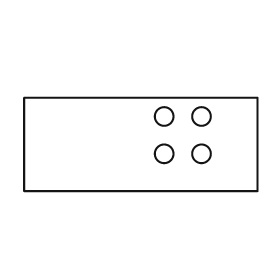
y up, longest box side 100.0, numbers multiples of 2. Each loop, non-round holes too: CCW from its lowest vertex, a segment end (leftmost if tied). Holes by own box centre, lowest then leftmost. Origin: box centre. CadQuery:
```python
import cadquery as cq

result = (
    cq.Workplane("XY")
    .moveTo(-50.0, -20.0)
    .lineTo(50.0, -20.0)
    .lineTo(50.0, 20.0)
    .lineTo(-50.0, 20.0)
    .close()
    .moveTo(10.0, -4.0)
    .circle(4.0)
    .moveTo(26.0, -4.0)
    .circle(4.0)
    .moveTo(10.0, 12.0)
    .circle(4.0)
    .moveTo(26.0, 12.0)
    .circle(4.0)
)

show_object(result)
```